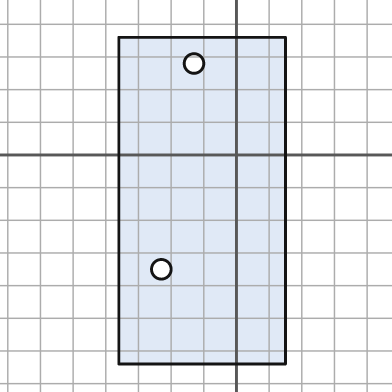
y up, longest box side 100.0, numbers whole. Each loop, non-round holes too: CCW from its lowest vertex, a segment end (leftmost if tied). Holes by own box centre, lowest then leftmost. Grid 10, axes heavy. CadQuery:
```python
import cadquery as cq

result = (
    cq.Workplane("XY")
    .moveTo(-36.0, -64.0)
    .lineTo(15.0, -64.0)
    .lineTo(15.0, 36.0)
    .lineTo(-36.0, 36.0)
    .close()
    .moveTo(-23.0, -35.0)
    .circle(3.0)
    .moveTo(-13.0, 28.0)
    .circle(3.0)
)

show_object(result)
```